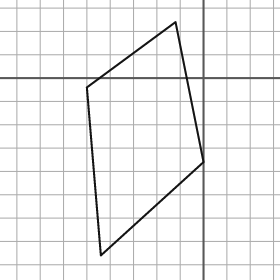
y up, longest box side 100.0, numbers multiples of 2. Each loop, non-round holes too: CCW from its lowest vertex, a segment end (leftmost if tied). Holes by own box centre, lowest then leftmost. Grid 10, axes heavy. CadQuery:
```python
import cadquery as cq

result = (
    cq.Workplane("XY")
    .moveTo(-44.0, -76.0)
    .lineTo(0.0, -36.0)
    .lineTo(-12.0, 24.0)
    .lineTo(-50.0, -4.0)
    .close()
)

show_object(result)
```